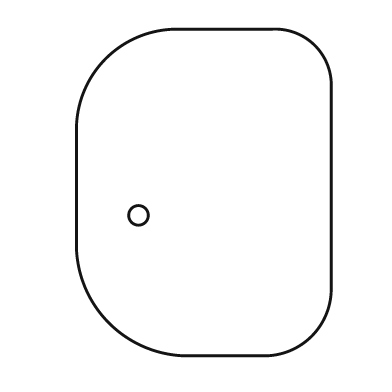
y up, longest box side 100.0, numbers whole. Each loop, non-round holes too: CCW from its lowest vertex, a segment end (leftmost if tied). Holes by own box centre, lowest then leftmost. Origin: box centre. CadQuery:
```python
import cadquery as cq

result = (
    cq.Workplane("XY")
    .moveTo(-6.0, -50.0)
    .lineTo(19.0, -50.0)
    .threePointArc((33.0, -44.0), (39.0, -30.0))
    .lineTo(39.0, 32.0)
    .threePointArc((34.0, 45.0), (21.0, 50.0))
    .lineTo(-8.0, 50.0)
    .threePointArc((-30.0, 41.0), (-39.0, 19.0))
    .lineTo(-39.0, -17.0)
    .threePointArc((-29.0, -40.0), (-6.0, -50.0))
    .close()
    .moveTo(-20.0, -7.0)
    .circle(3.0)
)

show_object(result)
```